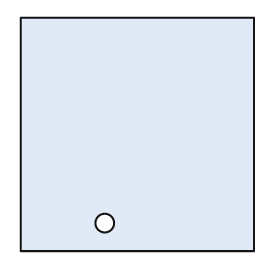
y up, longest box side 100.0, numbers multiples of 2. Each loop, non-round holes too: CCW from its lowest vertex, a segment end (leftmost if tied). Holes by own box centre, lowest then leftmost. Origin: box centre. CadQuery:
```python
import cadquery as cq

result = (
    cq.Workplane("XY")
    .moveTo(-50.0, -50.0)
    .lineTo(50.0, -50.0)
    .lineTo(50.0, 50.0)
    .lineTo(-50.0, 50.0)
    .close()
    .moveTo(-14.0, -38.0)
    .circle(4.0)
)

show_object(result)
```